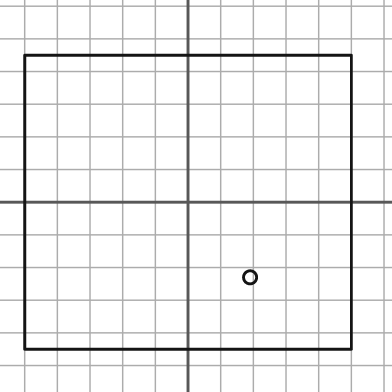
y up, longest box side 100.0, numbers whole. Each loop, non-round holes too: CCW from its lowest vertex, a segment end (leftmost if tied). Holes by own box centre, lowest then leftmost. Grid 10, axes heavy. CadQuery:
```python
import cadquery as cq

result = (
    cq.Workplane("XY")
    .moveTo(-50.0, -45.0)
    .lineTo(50.0, -45.0)
    .lineTo(50.0, 45.0)
    .lineTo(-50.0, 45.0)
    .close()
    .moveTo(19.0, -23.0)
    .circle(2.0)
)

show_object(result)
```